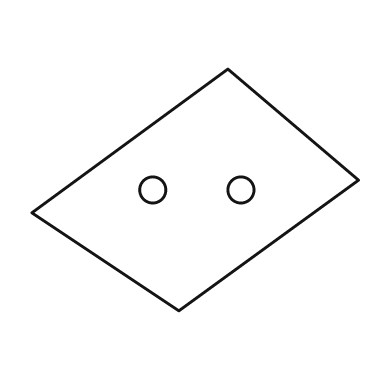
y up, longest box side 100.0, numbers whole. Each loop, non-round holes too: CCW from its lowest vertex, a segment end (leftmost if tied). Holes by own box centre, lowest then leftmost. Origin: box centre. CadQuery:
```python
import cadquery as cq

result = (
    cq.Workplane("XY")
    .moveTo(-5.0, -37.0)
    .lineTo(50.0, 3.0)
    .lineTo(10.0, 37.0)
    .lineTo(-50.0, -7.0)
    .close()
    .moveTo(-13.0, 0.0)
    .circle(4.0)
    .moveTo(14.0, 0.0)
    .circle(4.0)
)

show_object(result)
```